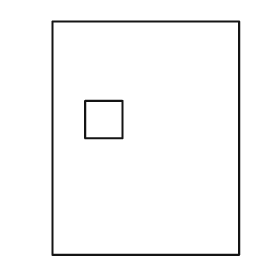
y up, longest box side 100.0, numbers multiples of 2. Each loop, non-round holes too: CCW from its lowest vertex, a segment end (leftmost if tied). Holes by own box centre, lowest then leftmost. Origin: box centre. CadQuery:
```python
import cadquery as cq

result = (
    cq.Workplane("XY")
    .moveTo(-40.0, -50.0)
    .lineTo(40.0, -50.0)
    .lineTo(40.0, 50.0)
    .lineTo(-40.0, 50.0)
    .close()
    .moveTo(-26.0, 0.0)
    .lineTo(-10.0, 0.0)
    .lineTo(-10.0, 16.0)
    .lineTo(-26.0, 16.0)
    .close()
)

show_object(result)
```